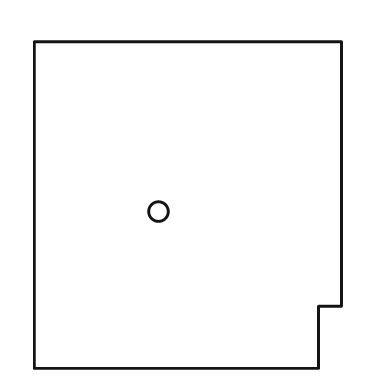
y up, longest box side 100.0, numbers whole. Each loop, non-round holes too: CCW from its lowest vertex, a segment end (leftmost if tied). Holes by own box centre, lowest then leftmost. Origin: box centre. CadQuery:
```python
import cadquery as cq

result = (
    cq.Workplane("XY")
    .moveTo(-47.0, -50.0)
    .lineTo(40.0, -50.0)
    .lineTo(40.0, -31.0)
    .lineTo(47.0, -31.0)
    .lineTo(47.0, 50.0)
    .lineTo(-47.0, 50.0)
    .close()
    .moveTo(-9.0, -2.0)
    .circle(3.0)
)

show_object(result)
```